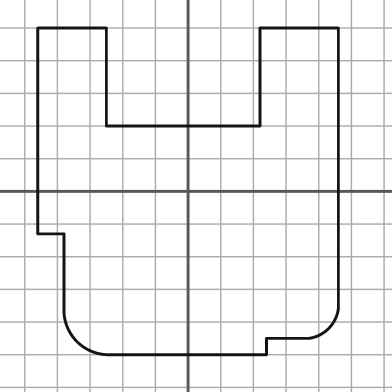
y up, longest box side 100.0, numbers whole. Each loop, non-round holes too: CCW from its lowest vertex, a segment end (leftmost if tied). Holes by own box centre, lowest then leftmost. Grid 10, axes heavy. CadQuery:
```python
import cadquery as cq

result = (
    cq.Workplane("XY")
    .moveTo(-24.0, -50.0)
    .lineTo(24.0, -50.0)
    .lineTo(24.0, -45.0)
    .lineTo(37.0, -45.0)
    .threePointArc((43.0, -42.0), (46.0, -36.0))
    .lineTo(46.0, 50.0)
    .lineTo(22.0, 50.0)
    .lineTo(22.0, 20.0)
    .lineTo(-25.0, 20.0)
    .lineTo(-25.0, 50.0)
    .lineTo(-46.0, 50.0)
    .lineTo(-46.0, -13.0)
    .lineTo(-38.0, -13.0)
    .lineTo(-38.0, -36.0)
    .threePointArc((-34.0, -46.0), (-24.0, -50.0))
    .close()
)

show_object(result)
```